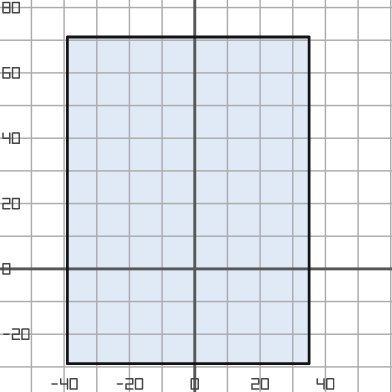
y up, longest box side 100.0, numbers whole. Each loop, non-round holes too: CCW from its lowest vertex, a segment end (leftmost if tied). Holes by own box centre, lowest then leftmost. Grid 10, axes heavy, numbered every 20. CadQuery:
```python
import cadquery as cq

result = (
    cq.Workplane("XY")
    .moveTo(-39.0, -29.0)
    .lineTo(35.0, -29.0)
    .lineTo(35.0, 71.0)
    .lineTo(-39.0, 71.0)
    .close()
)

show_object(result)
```